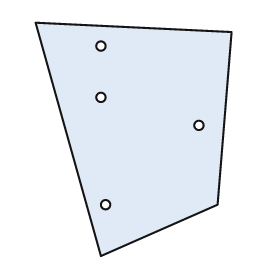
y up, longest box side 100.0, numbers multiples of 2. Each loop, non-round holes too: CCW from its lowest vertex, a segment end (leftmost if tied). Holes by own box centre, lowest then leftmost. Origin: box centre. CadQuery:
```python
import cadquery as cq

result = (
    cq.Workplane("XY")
    .moveTo(-14.0, -50.0)
    .lineTo(36.0, -28.0)
    .lineTo(42.0, 46.0)
    .lineTo(-42.0, 50.0)
    .close()
    .moveTo(-12.0, -28.0)
    .circle(2.0)
    .moveTo(28.0, 6.0)
    .circle(2.0)
    .moveTo(-14.0, 18.0)
    .circle(2.0)
    .moveTo(-14.0, 40.0)
    .circle(2.0)
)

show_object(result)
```